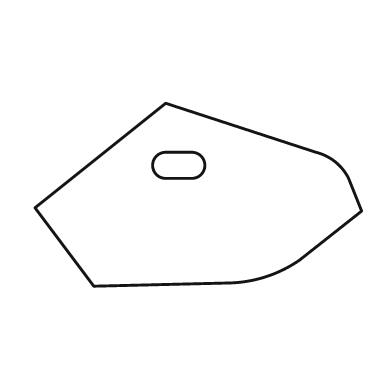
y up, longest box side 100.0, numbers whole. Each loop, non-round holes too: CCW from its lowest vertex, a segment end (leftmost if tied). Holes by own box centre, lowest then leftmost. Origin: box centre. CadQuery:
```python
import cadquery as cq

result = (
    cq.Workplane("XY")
    .moveTo(-32.0, -28.0)
    .lineTo(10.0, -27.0)
    .threePointArc((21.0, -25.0), (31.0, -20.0))
    .lineTo(50.0, -5.0)
    .lineTo(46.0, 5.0)
    .threePointArc((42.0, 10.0), (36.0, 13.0))
    .lineTo(-10.0, 28.0)
    .lineTo(-50.0, -4.0)
    .close()
    .moveTo(-10.0, 5.0)
    .lineTo(-2.0, 5.0)
    .threePointArc((2.0, 9.0), (-2.0, 13.0))
    .lineTo(-10.0, 13.0)
    .threePointArc((-14.0, 9.0), (-10.0, 5.0))
    .close()
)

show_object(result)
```